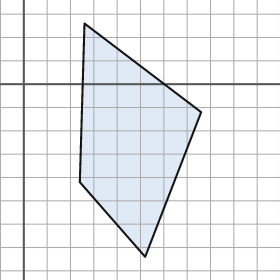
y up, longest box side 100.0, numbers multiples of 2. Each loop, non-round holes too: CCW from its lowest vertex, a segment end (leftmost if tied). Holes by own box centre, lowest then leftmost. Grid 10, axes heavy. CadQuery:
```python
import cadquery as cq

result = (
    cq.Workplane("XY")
    .moveTo(52.0, -74.0)
    .lineTo(76.0, -12.0)
    .lineTo(26.0, 26.0)
    .lineTo(24.0, -42.0)
    .close()
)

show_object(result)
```